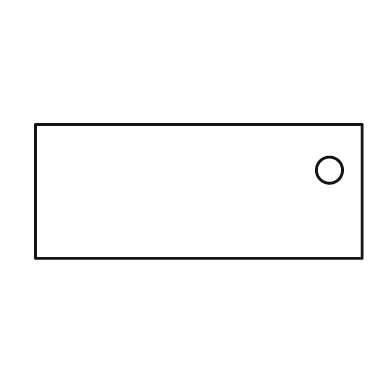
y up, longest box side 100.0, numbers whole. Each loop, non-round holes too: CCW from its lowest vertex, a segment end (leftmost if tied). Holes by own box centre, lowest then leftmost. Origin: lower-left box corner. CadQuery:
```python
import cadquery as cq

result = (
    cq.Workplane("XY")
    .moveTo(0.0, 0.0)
    .lineTo(100.0, 0.0)
    .lineTo(100.0, 41.0)
    .lineTo(0.0, 41.0)
    .close()
    .moveTo(90.0, 27.0)
    .circle(4.0)
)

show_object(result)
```